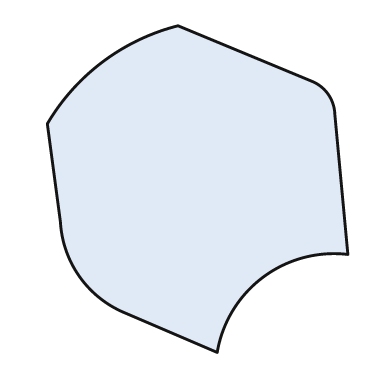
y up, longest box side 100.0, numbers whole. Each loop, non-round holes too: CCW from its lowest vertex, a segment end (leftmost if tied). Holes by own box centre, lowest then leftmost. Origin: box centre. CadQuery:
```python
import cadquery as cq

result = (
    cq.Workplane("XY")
    .moveTo(6.0, -50.0)
    .threePointArc((20.0, -27.0), (46.0, -20.0))
    .lineTo(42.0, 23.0)
    .threePointArc((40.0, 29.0), (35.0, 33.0))
    .lineTo(-6.0, 50.0)
    .threePointArc((-29.0, 39.0), (-46.0, 20.0))
    .lineTo(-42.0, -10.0)
    .threePointArc((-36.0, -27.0), (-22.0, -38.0))
    .close()
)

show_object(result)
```